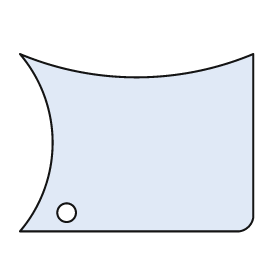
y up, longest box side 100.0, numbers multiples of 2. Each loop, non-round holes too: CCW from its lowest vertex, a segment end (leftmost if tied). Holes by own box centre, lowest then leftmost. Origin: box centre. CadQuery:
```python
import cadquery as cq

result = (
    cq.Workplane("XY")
    .moveTo(-50.0, -38.0)
    .lineTo(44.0, -38.0)
    .threePointArc((48.0, -36.0), (50.0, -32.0))
    .lineTo(50.0, 38.0)
    .threePointArc((0.0, 28.0), (-50.0, 38.0))
    .threePointArc((-36.0, 0.0), (-50.0, -38.0))
    .close()
    .moveTo(-30.0, -30.0)
    .circle(4.0)
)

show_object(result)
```